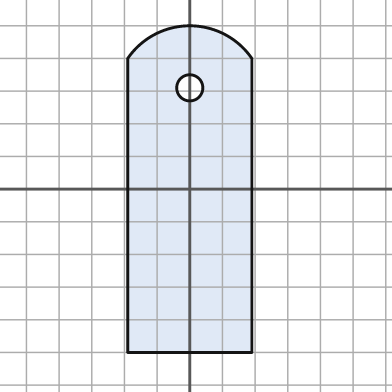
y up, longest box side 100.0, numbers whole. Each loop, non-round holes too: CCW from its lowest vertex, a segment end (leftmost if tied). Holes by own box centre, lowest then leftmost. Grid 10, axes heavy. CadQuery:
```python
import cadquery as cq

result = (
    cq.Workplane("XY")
    .moveTo(-19.0, -50.0)
    .lineTo(19.0, -50.0)
    .lineTo(19.0, 40.0)
    .threePointArc((0.0, 50.0), (-19.0, 40.0))
    .close()
    .moveTo(0.0, 31.0)
    .circle(4.0)
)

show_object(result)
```